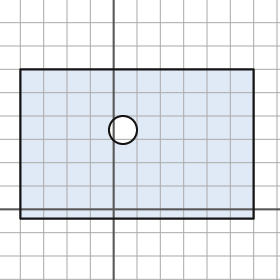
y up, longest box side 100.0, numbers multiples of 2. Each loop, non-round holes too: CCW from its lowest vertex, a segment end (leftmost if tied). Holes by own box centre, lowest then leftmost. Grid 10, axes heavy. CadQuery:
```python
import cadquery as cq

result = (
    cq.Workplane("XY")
    .moveTo(-40.0, -4.0)
    .lineTo(60.0, -4.0)
    .lineTo(60.0, 60.0)
    .lineTo(-40.0, 60.0)
    .close()
    .moveTo(4.0, 34.0)
    .circle(6.0)
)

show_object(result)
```